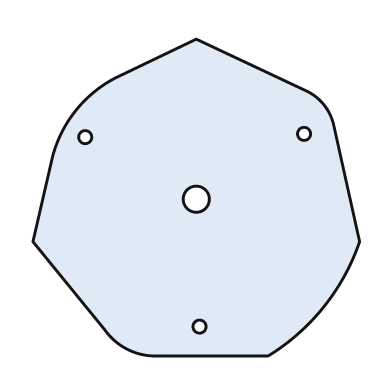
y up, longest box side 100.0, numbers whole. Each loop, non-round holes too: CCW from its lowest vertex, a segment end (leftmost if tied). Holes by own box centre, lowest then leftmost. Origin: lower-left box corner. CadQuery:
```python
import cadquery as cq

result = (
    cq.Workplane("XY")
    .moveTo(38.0, 0.0)
    .lineTo(72.0, 0.0)
    .threePointArc((89.0, 15.0), (100.0, 35.0))
    .lineTo(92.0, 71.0)
    .threePointArc((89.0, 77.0), (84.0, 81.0))
    .lineTo(50.0, 97.0)
    .lineTo(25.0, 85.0)
    .threePointArc((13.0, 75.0), (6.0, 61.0))
    .lineTo(0.0, 35.0)
    .lineTo(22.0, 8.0)
    .threePointArc((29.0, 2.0), (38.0, 0.0))
    .close()
    .moveTo(51.0, 9.0)
    .circle(2.0)
    .moveTo(50.0, 48.0)
    .circle(4.0)
    .moveTo(16.0, 67.0)
    .circle(2.0)
    .moveTo(83.0, 68.0)
    .circle(2.0)
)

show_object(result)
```